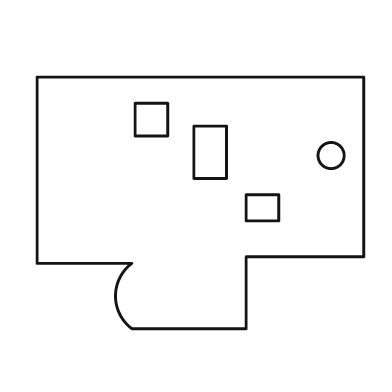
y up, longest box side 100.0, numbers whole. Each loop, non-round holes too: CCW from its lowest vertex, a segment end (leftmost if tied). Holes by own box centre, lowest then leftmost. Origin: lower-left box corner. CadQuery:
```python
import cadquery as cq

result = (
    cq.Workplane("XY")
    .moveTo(29.0, 0.0)
    .lineTo(64.0, 0.0)
    .lineTo(64.0, 22.0)
    .lineTo(100.0, 22.0)
    .lineTo(100.0, 77.0)
    .lineTo(0.0, 77.0)
    .lineTo(0.0, 20.0)
    .lineTo(29.0, 20.0)
    .threePointArc((24.0, 10.0), (29.0, 0.0))
    .close()
    .moveTo(64.0, 33.0)
    .lineTo(74.0, 33.0)
    .lineTo(74.0, 41.0)
    .lineTo(64.0, 41.0)
    .close()
    .moveTo(90.0, 53.0)
    .circle(4.0)
    .moveTo(48.0, 46.0)
    .lineTo(58.0, 46.0)
    .lineTo(58.0, 62.0)
    .lineTo(48.0, 62.0)
    .close()
    .moveTo(30.0, 59.0)
    .lineTo(40.0, 59.0)
    .lineTo(40.0, 69.0)
    .lineTo(30.0, 69.0)
    .close()
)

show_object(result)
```